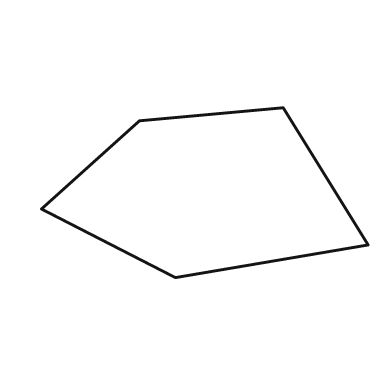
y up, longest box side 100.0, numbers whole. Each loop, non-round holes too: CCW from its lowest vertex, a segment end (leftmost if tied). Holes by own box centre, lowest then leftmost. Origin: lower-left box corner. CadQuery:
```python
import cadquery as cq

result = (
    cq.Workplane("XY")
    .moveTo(41.0, 0.0)
    .lineTo(100.0, 10.0)
    .lineTo(74.0, 52.0)
    .lineTo(30.0, 48.0)
    .lineTo(0.0, 21.0)
    .close()
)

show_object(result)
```